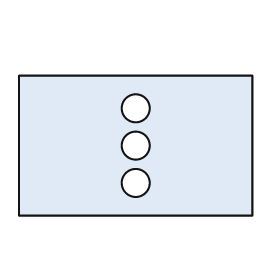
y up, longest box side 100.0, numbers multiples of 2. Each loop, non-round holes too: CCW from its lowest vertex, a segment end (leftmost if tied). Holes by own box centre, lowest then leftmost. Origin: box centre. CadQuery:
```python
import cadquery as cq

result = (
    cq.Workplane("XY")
    .moveTo(-50.0, -30.0)
    .lineTo(50.0, -30.0)
    .lineTo(50.0, 30.0)
    .lineTo(-50.0, 30.0)
    .close()
    .moveTo(0.0, -16.0)
    .circle(6.0)
    .moveTo(0.0, 0.0)
    .circle(6.0)
    .moveTo(0.0, 16.0)
    .circle(6.0)
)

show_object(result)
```